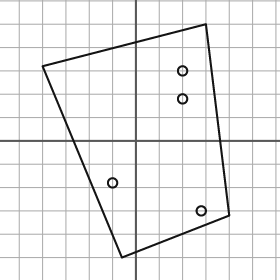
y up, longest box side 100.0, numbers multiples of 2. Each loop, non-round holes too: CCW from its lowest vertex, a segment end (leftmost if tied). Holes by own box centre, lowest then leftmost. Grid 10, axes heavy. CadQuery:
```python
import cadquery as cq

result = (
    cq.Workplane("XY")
    .moveTo(-6.0, -50.0)
    .lineTo(40.0, -32.0)
    .lineTo(30.0, 50.0)
    .lineTo(-40.0, 32.0)
    .close()
    .moveTo(28.0, -30.0)
    .circle(2.0)
    .moveTo(-10.0, -18.0)
    .circle(2.0)
    .moveTo(20.0, 18.0)
    .circle(2.0)
    .moveTo(20.0, 30.0)
    .circle(2.0)
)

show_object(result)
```